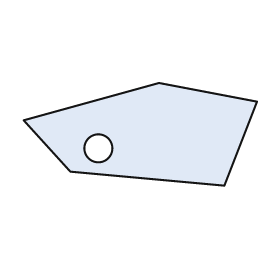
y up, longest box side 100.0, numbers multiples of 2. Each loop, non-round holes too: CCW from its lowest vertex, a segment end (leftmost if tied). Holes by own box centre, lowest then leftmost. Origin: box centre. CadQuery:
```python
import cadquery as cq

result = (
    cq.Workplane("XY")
    .moveTo(36.0, -22.0)
    .lineTo(50.0, 14.0)
    .lineTo(8.0, 22.0)
    .lineTo(-50.0, 6.0)
    .lineTo(-30.0, -16.0)
    .close()
    .moveTo(-18.0, -6.0)
    .circle(6.0)
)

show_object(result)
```